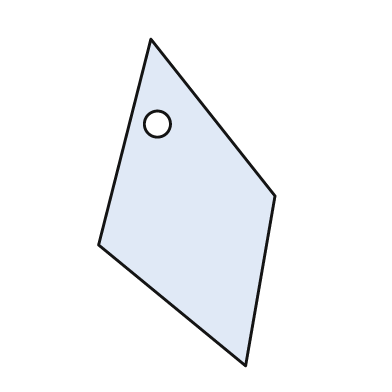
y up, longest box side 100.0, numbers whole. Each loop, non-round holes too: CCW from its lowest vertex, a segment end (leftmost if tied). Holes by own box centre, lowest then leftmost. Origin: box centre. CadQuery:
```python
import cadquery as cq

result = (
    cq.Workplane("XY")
    .moveTo(18.0, -50.0)
    .lineTo(27.0, 2.0)
    .lineTo(-11.0, 50.0)
    .lineTo(-27.0, -13.0)
    .close()
    .moveTo(-9.0, 24.0)
    .circle(4.0)
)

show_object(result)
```